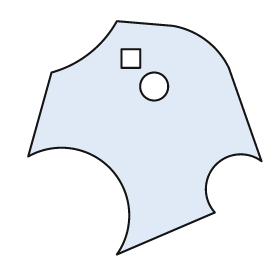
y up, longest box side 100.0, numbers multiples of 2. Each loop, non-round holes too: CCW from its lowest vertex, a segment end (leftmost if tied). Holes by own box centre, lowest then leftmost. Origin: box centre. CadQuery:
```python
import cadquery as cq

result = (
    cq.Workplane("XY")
    .moveTo(-12.0, -50.0)
    .lineTo(30.0, -32.0)
    .threePointArc((30.0, -12.0), (50.0, -10.0))
    .lineTo(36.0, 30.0)
    .threePointArc((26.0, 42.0), (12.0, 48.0))
    .lineTo(-12.0, 50.0)
    .threePointArc((-24.0, 36.0), (-40.0, 28.0))
    .lineTo(-50.0, -8.0)
    .threePointArc((-14.0, -14.0), (-12.0, -50.0))
    .close()
    .moveTo(4.0, 22.0)
    .circle(6.0)
    .moveTo(-10.0, 30.0)
    .lineTo(-2.0, 30.0)
    .lineTo(-2.0, 38.0)
    .lineTo(-10.0, 38.0)
    .close()
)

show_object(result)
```